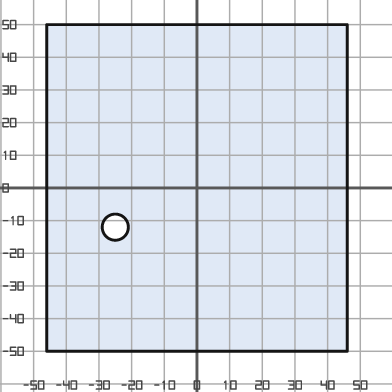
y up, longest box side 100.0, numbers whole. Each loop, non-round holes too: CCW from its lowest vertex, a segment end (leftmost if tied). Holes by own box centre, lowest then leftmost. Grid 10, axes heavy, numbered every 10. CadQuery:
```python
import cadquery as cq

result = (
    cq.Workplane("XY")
    .moveTo(-46.0, -50.0)
    .lineTo(46.0, -50.0)
    .lineTo(46.0, 50.0)
    .lineTo(-46.0, 50.0)
    .close()
    .moveTo(-25.0, -12.0)
    .circle(4.0)
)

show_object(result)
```